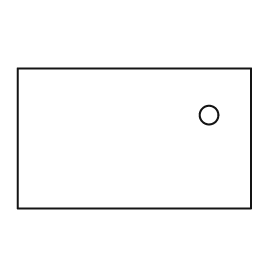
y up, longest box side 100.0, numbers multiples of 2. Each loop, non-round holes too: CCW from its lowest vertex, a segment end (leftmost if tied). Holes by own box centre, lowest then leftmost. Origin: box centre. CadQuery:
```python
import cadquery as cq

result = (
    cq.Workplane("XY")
    .moveTo(-50.0, -30.0)
    .lineTo(50.0, -30.0)
    .lineTo(50.0, 30.0)
    .lineTo(-50.0, 30.0)
    .close()
    .moveTo(32.0, 10.0)
    .circle(4.0)
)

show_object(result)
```